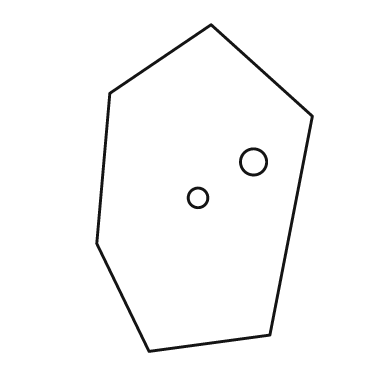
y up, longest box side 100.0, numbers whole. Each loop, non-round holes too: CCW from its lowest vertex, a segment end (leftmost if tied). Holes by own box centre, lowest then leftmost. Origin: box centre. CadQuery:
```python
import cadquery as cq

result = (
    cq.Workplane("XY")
    .moveTo(-17.0, -50.0)
    .lineTo(20.0, -45.0)
    .lineTo(33.0, 22.0)
    .lineTo(2.0, 50.0)
    .lineTo(-29.0, 29.0)
    .lineTo(-33.0, -17.0)
    .close()
    .moveTo(-2.0, -3.0)
    .circle(3.0)
    .moveTo(15.0, 8.0)
    .circle(4.0)
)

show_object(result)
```